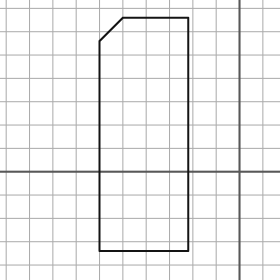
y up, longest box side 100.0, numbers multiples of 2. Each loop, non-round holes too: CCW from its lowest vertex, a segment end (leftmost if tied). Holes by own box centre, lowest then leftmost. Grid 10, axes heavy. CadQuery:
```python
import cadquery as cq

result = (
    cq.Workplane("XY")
    .moveTo(-60.0, -34.0)
    .lineTo(-22.0, -34.0)
    .lineTo(-22.0, 66.0)
    .lineTo(-50.0, 66.0)
    .lineTo(-60.0, 56.0)
    .close()
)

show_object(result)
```